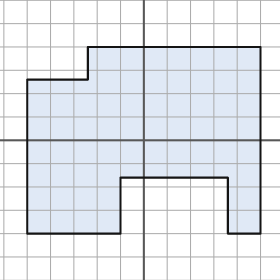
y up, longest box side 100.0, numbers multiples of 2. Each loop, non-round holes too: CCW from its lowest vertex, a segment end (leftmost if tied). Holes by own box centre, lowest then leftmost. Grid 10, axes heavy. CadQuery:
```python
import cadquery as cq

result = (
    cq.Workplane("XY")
    .moveTo(-50.0, -40.0)
    .lineTo(-10.0, -40.0)
    .lineTo(-10.0, -16.0)
    .lineTo(36.0, -16.0)
    .lineTo(36.0, -40.0)
    .lineTo(50.0, -40.0)
    .lineTo(50.0, 40.0)
    .lineTo(-24.0, 40.0)
    .lineTo(-24.0, 26.0)
    .lineTo(-50.0, 26.0)
    .close()
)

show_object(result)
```